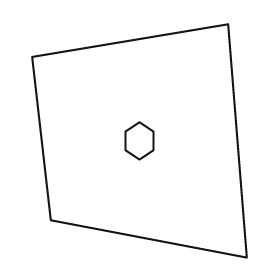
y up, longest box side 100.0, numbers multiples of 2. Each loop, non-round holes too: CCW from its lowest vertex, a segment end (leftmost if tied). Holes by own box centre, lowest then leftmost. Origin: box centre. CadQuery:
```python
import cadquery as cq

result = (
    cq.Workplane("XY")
    .moveTo(46.0, -50.0)
    .lineTo(38.0, 50.0)
    .lineTo(-46.0, 36.0)
    .lineTo(-38.0, -34.0)
    .close()
    .moveTo(0.0, -8.0)
    .lineTo(6.0, -4.0)
    .lineTo(6.0, 4.0)
    .lineTo(0.0, 8.0)
    .lineTo(-6.0, 4.0)
    .lineTo(-6.0, -4.0)
    .close()
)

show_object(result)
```